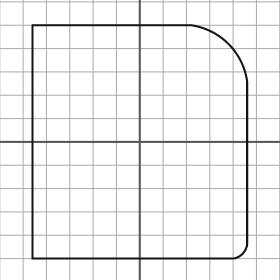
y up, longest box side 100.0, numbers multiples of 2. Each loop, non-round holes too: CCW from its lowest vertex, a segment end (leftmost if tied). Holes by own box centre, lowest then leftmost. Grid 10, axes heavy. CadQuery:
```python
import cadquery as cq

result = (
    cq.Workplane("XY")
    .moveTo(-46.0, -50.0)
    .lineTo(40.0, -50.0)
    .threePointArc((44.0, -48.0), (46.0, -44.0))
    .lineTo(46.0, 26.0)
    .threePointArc((38.0, 42.0), (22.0, 50.0))
    .lineTo(-46.0, 50.0)
    .close()
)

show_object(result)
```